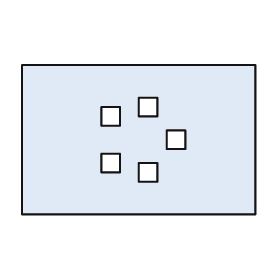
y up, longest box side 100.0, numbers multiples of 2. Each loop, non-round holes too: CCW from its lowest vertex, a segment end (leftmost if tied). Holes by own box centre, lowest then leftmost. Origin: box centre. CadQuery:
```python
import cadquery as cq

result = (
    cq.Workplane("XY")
    .moveTo(-50.0, -32.0)
    .lineTo(50.0, -32.0)
    .lineTo(50.0, 32.0)
    .lineTo(-50.0, 32.0)
    .close()
    .moveTo(0.0, -18.0)
    .lineTo(8.0, -18.0)
    .lineTo(8.0, -10.0)
    .lineTo(0.0, -10.0)
    .close()
    .moveTo(-16.0, -14.0)
    .lineTo(-8.0, -14.0)
    .lineTo(-8.0, -6.0)
    .lineTo(-16.0, -6.0)
    .close()
    .moveTo(12.0, -4.0)
    .lineTo(20.0, -4.0)
    .lineTo(20.0, 4.0)
    .lineTo(12.0, 4.0)
    .close()
    .moveTo(-16.0, 6.0)
    .lineTo(-8.0, 6.0)
    .lineTo(-8.0, 14.0)
    .lineTo(-16.0, 14.0)
    .close()
    .moveTo(0.0, 10.0)
    .lineTo(8.0, 10.0)
    .lineTo(8.0, 18.0)
    .lineTo(0.0, 18.0)
    .close()
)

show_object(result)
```